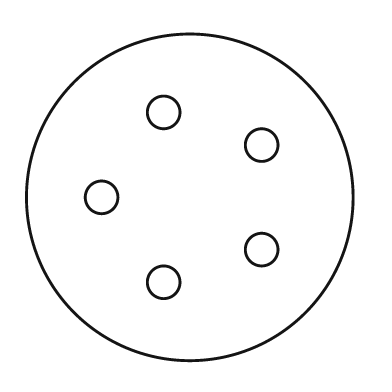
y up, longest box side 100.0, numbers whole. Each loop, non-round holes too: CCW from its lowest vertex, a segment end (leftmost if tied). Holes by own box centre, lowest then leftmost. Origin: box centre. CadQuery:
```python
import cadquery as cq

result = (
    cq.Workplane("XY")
    .moveTo(0.0, 0.0)
    .circle(50.0)
    .moveTo(-8.0, -26.0)
    .circle(5.0)
    .moveTo(22.0, -16.0)
    .circle(5.0)
    .moveTo(-27.0, 0.0)
    .circle(5.0)
    .moveTo(22.0, 16.0)
    .circle(5.0)
    .moveTo(-8.0, 26.0)
    .circle(5.0)
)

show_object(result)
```